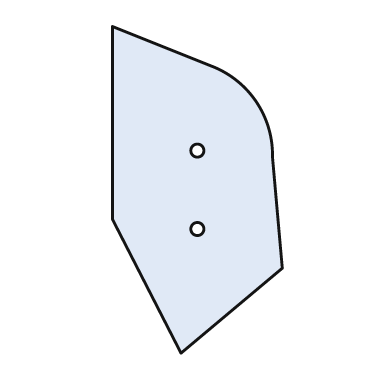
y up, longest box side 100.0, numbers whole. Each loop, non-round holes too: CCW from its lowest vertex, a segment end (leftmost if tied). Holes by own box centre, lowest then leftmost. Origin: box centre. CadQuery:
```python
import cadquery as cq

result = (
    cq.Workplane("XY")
    .moveTo(-5.0, -50.0)
    .lineTo(26.0, -24.0)
    .lineTo(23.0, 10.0)
    .threePointArc((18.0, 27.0), (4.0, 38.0))
    .lineTo(-26.0, 50.0)
    .lineTo(-26.0, -9.0)
    .close()
    .moveTo(0.0, -12.0)
    .circle(2.0)
    .moveTo(0.0, 12.0)
    .circle(2.0)
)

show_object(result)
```